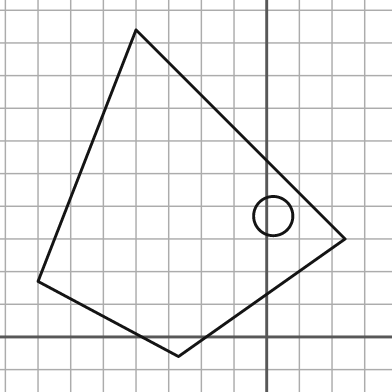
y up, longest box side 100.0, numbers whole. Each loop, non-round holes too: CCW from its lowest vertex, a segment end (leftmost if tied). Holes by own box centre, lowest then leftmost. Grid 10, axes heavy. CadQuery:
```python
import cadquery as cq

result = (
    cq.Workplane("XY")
    .moveTo(-27.0, -6.0)
    .lineTo(24.0, 30.0)
    .lineTo(-40.0, 94.0)
    .lineTo(-70.0, 17.0)
    .close()
    .moveTo(2.0, 37.0)
    .circle(6.0)
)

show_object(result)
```